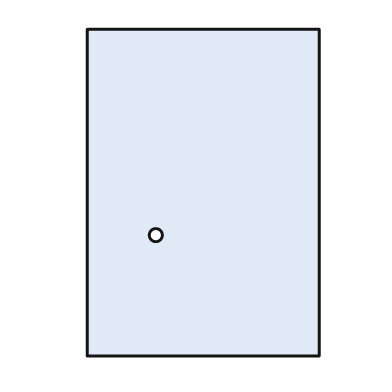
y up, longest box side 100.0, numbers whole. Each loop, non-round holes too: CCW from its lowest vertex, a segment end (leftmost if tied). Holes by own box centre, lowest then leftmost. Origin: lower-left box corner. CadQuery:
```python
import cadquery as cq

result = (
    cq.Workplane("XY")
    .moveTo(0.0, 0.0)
    .lineTo(71.0, 0.0)
    .lineTo(71.0, 100.0)
    .lineTo(0.0, 100.0)
    .close()
    .moveTo(21.0, 37.0)
    .circle(2.0)
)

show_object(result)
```